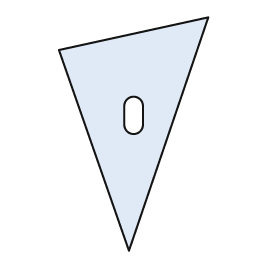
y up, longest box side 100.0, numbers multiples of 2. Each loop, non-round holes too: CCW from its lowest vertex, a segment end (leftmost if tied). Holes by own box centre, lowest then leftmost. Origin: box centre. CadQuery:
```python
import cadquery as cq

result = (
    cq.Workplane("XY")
    .moveTo(-2.0, -50.0)
    .lineTo(32.0, 50.0)
    .lineTo(-32.0, 36.0)
    .close()
    .moveTo(-4.0, 4.0)
    .threePointArc((0.0, 0.0), (4.0, 4.0))
    .lineTo(4.0, 12.0)
    .threePointArc((0.0, 16.0), (-4.0, 12.0))
    .close()
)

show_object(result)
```